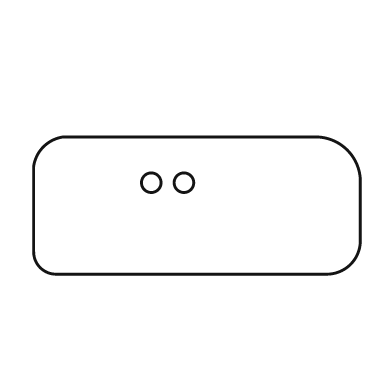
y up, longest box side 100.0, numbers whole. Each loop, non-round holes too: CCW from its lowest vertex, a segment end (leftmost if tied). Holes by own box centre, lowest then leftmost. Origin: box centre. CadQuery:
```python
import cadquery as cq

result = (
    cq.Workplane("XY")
    .moveTo(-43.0, -21.0)
    .lineTo(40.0, -21.0)
    .threePointArc((47.0, -18.0), (50.0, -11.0))
    .lineTo(50.0, 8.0)
    .threePointArc((46.0, 17.0), (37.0, 21.0))
    .lineTo(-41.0, 21.0)
    .threePointArc((-47.0, 18.0), (-50.0, 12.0))
    .lineTo(-50.0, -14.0)
    .threePointArc((-48.0, -19.0), (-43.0, -21.0))
    .close()
    .moveTo(-14.0, 7.0)
    .circle(3.0)
    .moveTo(-4.0, 7.0)
    .circle(3.0)
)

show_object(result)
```